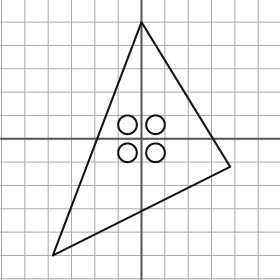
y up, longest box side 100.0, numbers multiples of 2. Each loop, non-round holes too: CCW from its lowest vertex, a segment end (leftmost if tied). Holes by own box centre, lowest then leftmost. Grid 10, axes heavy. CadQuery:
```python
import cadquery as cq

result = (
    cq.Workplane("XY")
    .moveTo(-38.0, -50.0)
    .lineTo(38.0, -12.0)
    .lineTo(0.0, 50.0)
    .close()
    .moveTo(-6.0, -6.0)
    .circle(4.0)
    .moveTo(6.0, -6.0)
    .circle(4.0)
    .moveTo(-6.0, 6.0)
    .circle(4.0)
    .moveTo(6.0, 6.0)
    .circle(4.0)
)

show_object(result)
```